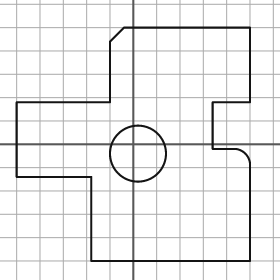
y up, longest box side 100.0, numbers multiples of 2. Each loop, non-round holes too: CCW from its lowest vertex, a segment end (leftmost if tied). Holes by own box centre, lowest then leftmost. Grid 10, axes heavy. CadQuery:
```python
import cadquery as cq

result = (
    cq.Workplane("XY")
    .moveTo(-18.0, -50.0)
    .lineTo(50.0, -50.0)
    .lineTo(50.0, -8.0)
    .threePointArc((48.0, -4.0), (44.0, -2.0))
    .lineTo(34.0, -2.0)
    .lineTo(34.0, 18.0)
    .lineTo(50.0, 18.0)
    .lineTo(50.0, 50.0)
    .lineTo(-4.0, 50.0)
    .lineTo(-10.0, 44.0)
    .lineTo(-10.0, 18.0)
    .lineTo(-50.0, 18.0)
    .lineTo(-50.0, -14.0)
    .lineTo(-18.0, -14.0)
    .close()
    .moveTo(2.0, -4.0)
    .circle(12.0)
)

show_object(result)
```